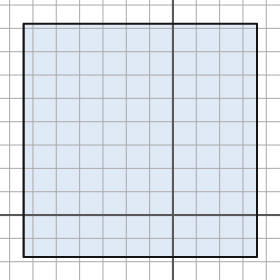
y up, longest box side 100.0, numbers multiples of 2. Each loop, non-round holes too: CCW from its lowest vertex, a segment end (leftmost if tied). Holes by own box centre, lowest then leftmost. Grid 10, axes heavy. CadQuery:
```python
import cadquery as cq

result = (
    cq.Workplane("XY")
    .moveTo(-64.0, -18.0)
    .lineTo(36.0, -18.0)
    .lineTo(36.0, 82.0)
    .lineTo(-64.0, 82.0)
    .close()
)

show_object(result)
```